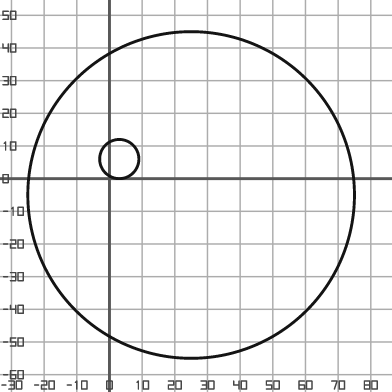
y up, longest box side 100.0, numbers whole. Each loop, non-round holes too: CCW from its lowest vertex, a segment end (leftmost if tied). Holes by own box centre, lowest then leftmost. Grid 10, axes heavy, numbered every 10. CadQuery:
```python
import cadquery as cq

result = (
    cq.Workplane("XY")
    .moveTo(25.0, -5.0)
    .circle(50.0)
    .moveTo(3.0, 6.0)
    .circle(6.0)
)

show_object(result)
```